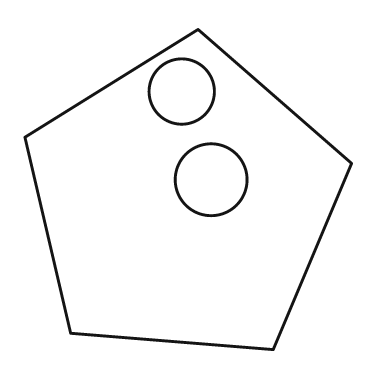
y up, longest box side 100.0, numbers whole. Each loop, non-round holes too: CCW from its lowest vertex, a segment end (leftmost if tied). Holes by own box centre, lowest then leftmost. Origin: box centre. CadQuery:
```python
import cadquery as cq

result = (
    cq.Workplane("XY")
    .moveTo(26.0, -49.0)
    .lineTo(50.0, 8.0)
    .lineTo(3.0, 49.0)
    .lineTo(-50.0, 16.0)
    .lineTo(-36.0, -44.0)
    .close()
    .moveTo(7.0, 3.0)
    .circle(11.0)
    .moveTo(-2.0, 30.0)
    .circle(10.0)
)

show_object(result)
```